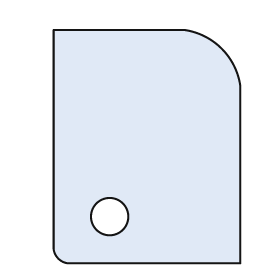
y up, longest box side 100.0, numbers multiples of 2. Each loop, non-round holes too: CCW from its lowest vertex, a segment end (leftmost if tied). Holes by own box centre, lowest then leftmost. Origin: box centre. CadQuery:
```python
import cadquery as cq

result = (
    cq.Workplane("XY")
    .moveTo(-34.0, -50.0)
    .lineTo(40.0, -50.0)
    .lineTo(40.0, 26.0)
    .threePointArc((32.0, 42.0), (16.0, 50.0))
    .lineTo(-40.0, 50.0)
    .lineTo(-40.0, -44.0)
    .threePointArc((-38.0, -48.0), (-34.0, -50.0))
    .close()
    .moveTo(-16.0, -30.0)
    .circle(8.0)
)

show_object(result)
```